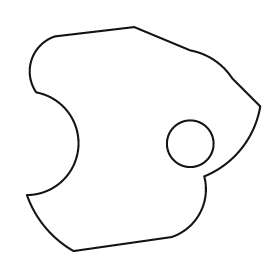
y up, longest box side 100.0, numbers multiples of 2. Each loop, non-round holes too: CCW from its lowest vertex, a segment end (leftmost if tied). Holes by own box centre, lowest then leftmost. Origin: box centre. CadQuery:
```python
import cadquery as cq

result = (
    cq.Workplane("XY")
    .moveTo(-30.0, -48.0)
    .lineTo(12.0, -42.0)
    .threePointArc((24.0, -32.0), (26.0, -16.0))
    .threePointArc((42.0, -4.0), (50.0, 14.0))
    .lineTo(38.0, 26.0)
    .threePointArc((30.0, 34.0), (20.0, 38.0))
    .lineTo(-4.0, 48.0)
    .lineTo(-38.0, 44.0)
    .threePointArc((-48.0, 34.0), (-46.0, 20.0))
    .threePointArc((-28.0, -4.0), (-50.0, -24.0))
    .threePointArc((-42.0, -38.0), (-30.0, -48.0))
    .close()
    .moveTo(20.0, -2.0)
    .circle(10.0)
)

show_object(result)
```